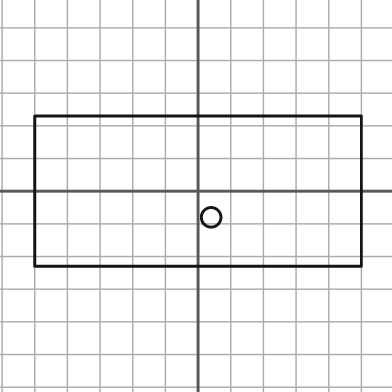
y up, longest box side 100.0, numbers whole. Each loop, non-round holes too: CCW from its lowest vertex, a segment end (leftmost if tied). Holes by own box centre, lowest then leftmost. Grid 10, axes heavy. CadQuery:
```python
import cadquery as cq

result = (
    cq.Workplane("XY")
    .moveTo(-50.0, -23.0)
    .lineTo(50.0, -23.0)
    .lineTo(50.0, 23.0)
    .lineTo(-50.0, 23.0)
    .close()
    .moveTo(4.0, -8.0)
    .circle(3.0)
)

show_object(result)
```